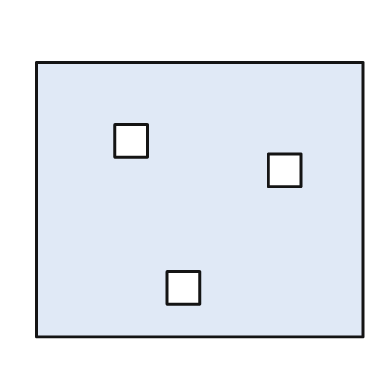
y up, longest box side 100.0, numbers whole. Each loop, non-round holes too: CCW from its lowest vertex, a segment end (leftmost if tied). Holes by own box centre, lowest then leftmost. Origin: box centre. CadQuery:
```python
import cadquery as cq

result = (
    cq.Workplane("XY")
    .moveTo(-50.0, -42.0)
    .lineTo(50.0, -42.0)
    .lineTo(50.0, 42.0)
    .lineTo(-50.0, 42.0)
    .close()
    .moveTo(-10.0, -32.0)
    .lineTo(0.0, -32.0)
    .lineTo(0.0, -22.0)
    .lineTo(-10.0, -22.0)
    .close()
    .moveTo(21.0, 4.0)
    .lineTo(31.0, 4.0)
    .lineTo(31.0, 14.0)
    .lineTo(21.0, 14.0)
    .close()
    .moveTo(-26.0, 13.0)
    .lineTo(-16.0, 13.0)
    .lineTo(-16.0, 23.0)
    .lineTo(-26.0, 23.0)
    .close()
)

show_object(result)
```